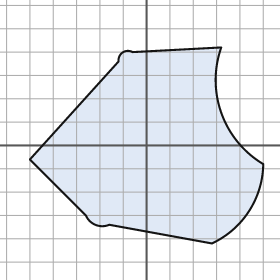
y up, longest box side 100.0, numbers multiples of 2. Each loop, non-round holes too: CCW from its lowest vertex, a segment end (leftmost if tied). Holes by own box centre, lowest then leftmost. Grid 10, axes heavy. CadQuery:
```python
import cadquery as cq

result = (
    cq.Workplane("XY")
    .moveTo(28.0, -42.0)
    .threePointArc((44.0, -28.0), (50.0, -8.0))
    .threePointArc((32.0, 14.0), (32.0, 42.0))
    .lineTo(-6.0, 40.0)
    .threePointArc((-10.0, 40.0), (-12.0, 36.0))
    .lineTo(-50.0, -6.0)
    .lineTo(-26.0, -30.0)
    .threePointArc((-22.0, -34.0), (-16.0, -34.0))
    .close()
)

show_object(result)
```